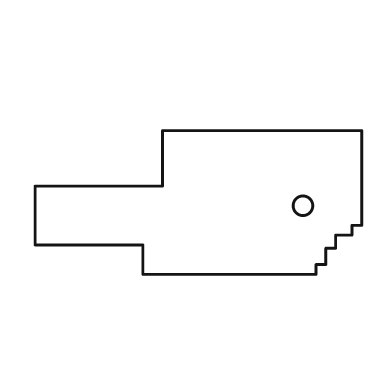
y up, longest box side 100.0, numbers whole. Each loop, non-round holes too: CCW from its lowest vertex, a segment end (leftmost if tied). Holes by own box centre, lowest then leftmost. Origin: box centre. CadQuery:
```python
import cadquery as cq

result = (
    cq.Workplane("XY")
    .moveTo(-17.0, -22.0)
    .lineTo(36.0, -22.0)
    .lineTo(36.0, -19.0)
    .lineTo(39.0, -19.0)
    .lineTo(39.0, -14.0)
    .lineTo(42.0, -14.0)
    .lineTo(42.0, -10.0)
    .lineTo(47.0, -10.0)
    .lineTo(47.0, -7.0)
    .lineTo(50.0, -7.0)
    .lineTo(50.0, 22.0)
    .lineTo(-11.0, 22.0)
    .lineTo(-11.0, 5.0)
    .lineTo(-50.0, 5.0)
    .lineTo(-50.0, -13.0)
    .lineTo(-17.0, -13.0)
    .close()
    .moveTo(32.0, -1.0)
    .circle(3.0)
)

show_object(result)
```